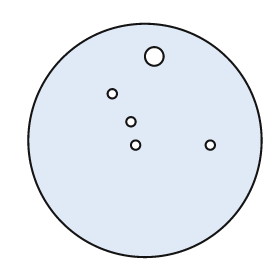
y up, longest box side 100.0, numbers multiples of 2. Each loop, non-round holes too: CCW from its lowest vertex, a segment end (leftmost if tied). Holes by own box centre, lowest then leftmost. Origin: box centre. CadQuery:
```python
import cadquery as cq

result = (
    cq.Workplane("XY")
    .moveTo(0.0, 0.0)
    .circle(50.0)
    .moveTo(-4.0, -2.0)
    .circle(2.0)
    .moveTo(28.0, -2.0)
    .circle(2.0)
    .moveTo(-6.0, 8.0)
    .circle(2.0)
    .moveTo(-14.0, 20.0)
    .circle(2.0)
    .moveTo(4.0, 36.0)
    .circle(4.0)
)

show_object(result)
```